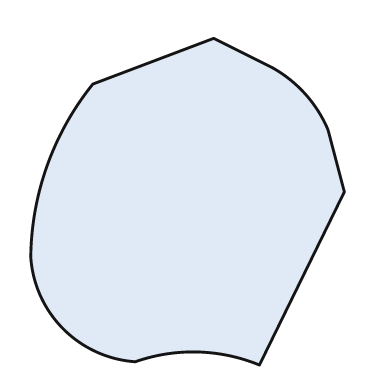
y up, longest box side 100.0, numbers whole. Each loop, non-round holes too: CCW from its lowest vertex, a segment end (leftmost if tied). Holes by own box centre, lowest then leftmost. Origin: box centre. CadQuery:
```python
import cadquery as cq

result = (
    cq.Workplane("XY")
    .moveTo(22.0, -50.0)
    .lineTo(48.0, 3.0)
    .lineTo(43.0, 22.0)
    .threePointArc((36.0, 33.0), (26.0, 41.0))
    .lineTo(8.0, 50.0)
    .lineTo(-29.0, 36.0)
    .threePointArc((-43.0, 11.0), (-48.0, -17.0))
    .threePointArc((-38.0, -39.0), (-16.0, -49.0))
    .threePointArc((3.0, -46.0), (22.0, -50.0))
    .close()
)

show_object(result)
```